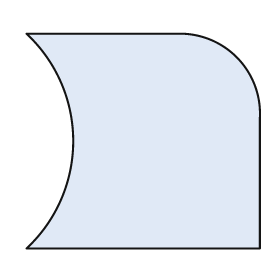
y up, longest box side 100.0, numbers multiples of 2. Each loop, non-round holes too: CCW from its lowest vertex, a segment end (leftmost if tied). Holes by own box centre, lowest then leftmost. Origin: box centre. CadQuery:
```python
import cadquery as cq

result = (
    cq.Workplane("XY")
    .moveTo(-50.0, -46.0)
    .lineTo(50.0, -46.0)
    .lineTo(50.0, 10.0)
    .threePointArc((40.0, 36.0), (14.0, 46.0))
    .lineTo(-50.0, 46.0)
    .threePointArc((-30.0, 0.0), (-50.0, -46.0))
    .close()
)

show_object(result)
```